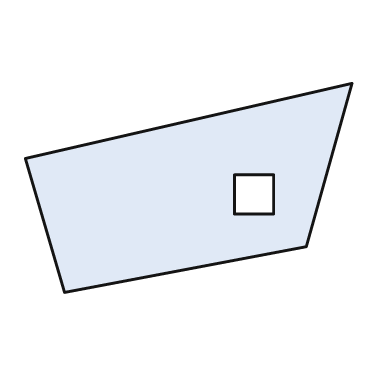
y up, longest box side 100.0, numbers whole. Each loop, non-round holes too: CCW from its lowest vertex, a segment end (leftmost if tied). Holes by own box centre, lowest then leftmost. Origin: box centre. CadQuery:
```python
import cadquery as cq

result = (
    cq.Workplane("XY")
    .moveTo(-38.0, -32.0)
    .lineTo(36.0, -18.0)
    .lineTo(50.0, 32.0)
    .lineTo(-50.0, 9.0)
    .close()
    .moveTo(14.0, -8.0)
    .lineTo(26.0, -8.0)
    .lineTo(26.0, 4.0)
    .lineTo(14.0, 4.0)
    .close()
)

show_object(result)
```